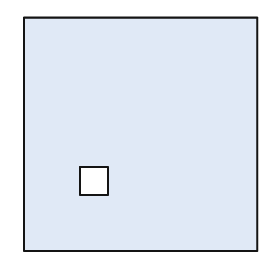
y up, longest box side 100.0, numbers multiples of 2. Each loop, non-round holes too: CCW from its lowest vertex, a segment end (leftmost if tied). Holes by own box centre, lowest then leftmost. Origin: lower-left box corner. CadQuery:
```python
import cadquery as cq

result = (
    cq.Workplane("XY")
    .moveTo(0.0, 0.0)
    .lineTo(100.0, 0.0)
    .lineTo(100.0, 100.0)
    .lineTo(0.0, 100.0)
    .close()
    .moveTo(24.0, 24.0)
    .lineTo(36.0, 24.0)
    .lineTo(36.0, 36.0)
    .lineTo(24.0, 36.0)
    .close()
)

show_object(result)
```